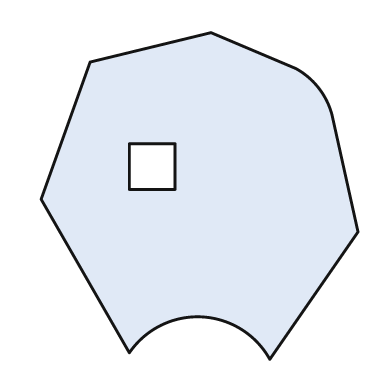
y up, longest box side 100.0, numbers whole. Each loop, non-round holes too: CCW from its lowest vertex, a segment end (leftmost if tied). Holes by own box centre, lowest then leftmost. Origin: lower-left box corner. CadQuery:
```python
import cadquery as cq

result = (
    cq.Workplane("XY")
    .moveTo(70.0, 0.0)
    .lineTo(97.0, 39.0)
    .lineTo(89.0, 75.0)
    .threePointArc((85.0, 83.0), (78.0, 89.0))
    .lineTo(52.0, 100.0)
    .lineTo(15.0, 91.0)
    .lineTo(0.0, 49.0)
    .lineTo(27.0, 2.0)
    .threePointArc((49.0, 13.0), (70.0, 0.0))
    .close()
    .moveTo(27.0, 52.0)
    .lineTo(41.0, 52.0)
    .lineTo(41.0, 66.0)
    .lineTo(27.0, 66.0)
    .close()
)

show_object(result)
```